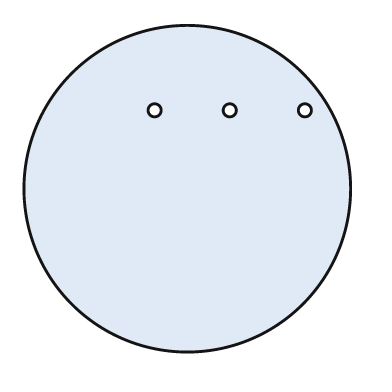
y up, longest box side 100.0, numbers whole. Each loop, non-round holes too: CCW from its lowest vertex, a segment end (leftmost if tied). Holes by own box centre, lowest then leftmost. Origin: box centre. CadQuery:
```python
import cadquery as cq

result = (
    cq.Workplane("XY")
    .moveTo(0.0, 0.0)
    .circle(50.0)
    .moveTo(-10.0, 24.0)
    .circle(2.0)
    .moveTo(13.0, 24.0)
    .circle(2.0)
    .moveTo(36.0, 24.0)
    .circle(2.0)
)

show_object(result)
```